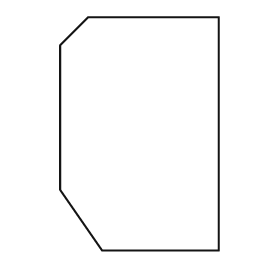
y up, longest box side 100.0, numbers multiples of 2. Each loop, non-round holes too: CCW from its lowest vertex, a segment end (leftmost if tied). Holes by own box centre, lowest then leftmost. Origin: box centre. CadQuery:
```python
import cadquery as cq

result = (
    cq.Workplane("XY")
    .moveTo(-16.0, -50.0)
    .lineTo(34.0, -50.0)
    .lineTo(34.0, 50.0)
    .lineTo(-22.0, 50.0)
    .lineTo(-34.0, 38.0)
    .lineTo(-34.0, -24.0)
    .close()
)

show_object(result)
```